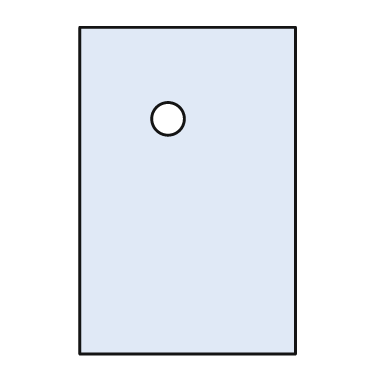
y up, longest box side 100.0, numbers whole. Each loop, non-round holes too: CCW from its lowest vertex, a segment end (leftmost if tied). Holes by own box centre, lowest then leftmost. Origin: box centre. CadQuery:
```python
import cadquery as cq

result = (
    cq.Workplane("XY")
    .moveTo(-33.0, -50.0)
    .lineTo(33.0, -50.0)
    .lineTo(33.0, 50.0)
    .lineTo(-33.0, 50.0)
    .close()
    .moveTo(-6.0, 22.0)
    .circle(5.0)
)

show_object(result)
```